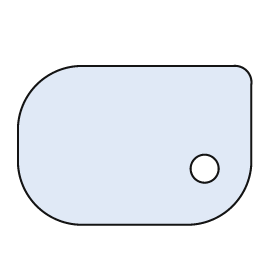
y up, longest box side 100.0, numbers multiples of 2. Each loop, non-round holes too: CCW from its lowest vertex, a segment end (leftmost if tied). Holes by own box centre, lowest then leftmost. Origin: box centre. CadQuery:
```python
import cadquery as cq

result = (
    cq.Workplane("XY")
    .moveTo(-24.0, -34.0)
    .lineTo(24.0, -34.0)
    .threePointArc((42.0, -26.0), (50.0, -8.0))
    .lineTo(50.0, 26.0)
    .threePointArc((48.0, 32.0), (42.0, 34.0))
    .lineTo(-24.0, 34.0)
    .threePointArc((-42.0, 26.0), (-50.0, 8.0))
    .lineTo(-50.0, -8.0)
    .threePointArc((-42.0, -26.0), (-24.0, -34.0))
    .close()
    .moveTo(30.0, -10.0)
    .circle(6.0)
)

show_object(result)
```